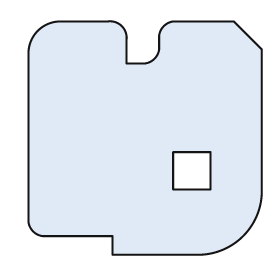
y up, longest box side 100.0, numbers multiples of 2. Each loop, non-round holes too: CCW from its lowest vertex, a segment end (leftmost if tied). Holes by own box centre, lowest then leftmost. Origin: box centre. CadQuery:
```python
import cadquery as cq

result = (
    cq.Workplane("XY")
    .moveTo(-14.0, -50.0)
    .lineTo(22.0, -50.0)
    .threePointArc((42.0, -42.0), (50.0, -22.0))
    .lineTo(50.0, 38.0)
    .lineTo(38.0, 50.0)
    .lineTo(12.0, 50.0)
    .threePointArc((8.0, 48.0), (6.0, 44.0))
    .lineTo(6.0, 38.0)
    .threePointArc((4.0, 34.0), (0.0, 32.0))
    .lineTo(-8.0, 32.0)
    .lineTo(-8.0, 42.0)
    .threePointArc((-10.0, 48.0), (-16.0, 50.0))
    .lineTo(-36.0, 50.0)
    .threePointArc((-46.0, 46.0), (-50.0, 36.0))
    .lineTo(-50.0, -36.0)
    .threePointArc((-48.0, -40.0), (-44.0, -42.0))
    .lineTo(-14.0, -42.0)
    .close()
    .moveTo(12.0, -22.0)
    .lineTo(28.0, -22.0)
    .lineTo(28.0, -6.0)
    .lineTo(12.0, -6.0)
    .close()
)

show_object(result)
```